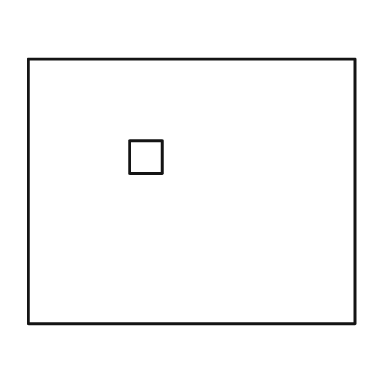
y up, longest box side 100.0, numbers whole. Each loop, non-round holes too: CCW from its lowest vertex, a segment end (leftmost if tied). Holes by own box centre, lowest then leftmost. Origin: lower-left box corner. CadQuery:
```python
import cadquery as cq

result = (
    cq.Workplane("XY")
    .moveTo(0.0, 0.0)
    .lineTo(100.0, 0.0)
    .lineTo(100.0, 81.0)
    .lineTo(0.0, 81.0)
    .close()
    .moveTo(31.0, 46.0)
    .lineTo(41.0, 46.0)
    .lineTo(41.0, 56.0)
    .lineTo(31.0, 56.0)
    .close()
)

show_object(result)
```